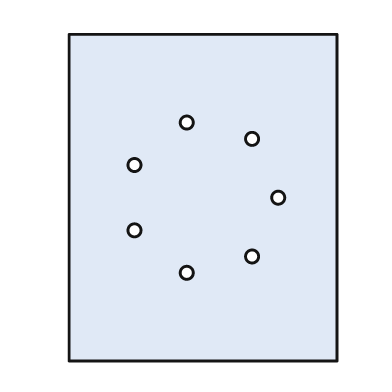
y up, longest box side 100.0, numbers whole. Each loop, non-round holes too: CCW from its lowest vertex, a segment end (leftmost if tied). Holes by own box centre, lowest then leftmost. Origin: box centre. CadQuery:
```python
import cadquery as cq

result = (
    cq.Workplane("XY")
    .moveTo(-41.0, -50.0)
    .lineTo(41.0, -50.0)
    .lineTo(41.0, 50.0)
    .lineTo(-41.0, 50.0)
    .close()
    .moveTo(-5.0, -23.0)
    .circle(2.0)
    .moveTo(15.0, -18.0)
    .circle(2.0)
    .moveTo(-21.0, -10.0)
    .circle(2.0)
    .moveTo(23.0, 0.0)
    .circle(2.0)
    .moveTo(-21.0, 10.0)
    .circle(2.0)
    .moveTo(15.0, 18.0)
    .circle(2.0)
    .moveTo(-5.0, 23.0)
    .circle(2.0)
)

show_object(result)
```